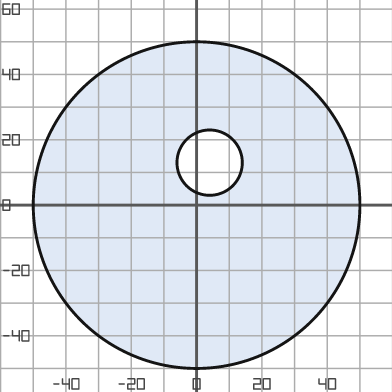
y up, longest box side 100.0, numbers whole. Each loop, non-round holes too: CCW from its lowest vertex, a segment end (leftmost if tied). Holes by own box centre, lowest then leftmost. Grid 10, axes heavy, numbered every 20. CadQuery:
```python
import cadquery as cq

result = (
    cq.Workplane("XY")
    .moveTo(0.0, 0.0)
    .circle(50.0)
    .moveTo(4.0, 13.0)
    .circle(10.0)
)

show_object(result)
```